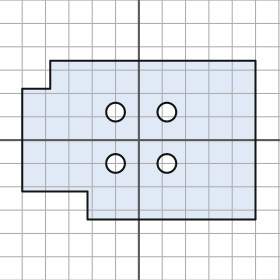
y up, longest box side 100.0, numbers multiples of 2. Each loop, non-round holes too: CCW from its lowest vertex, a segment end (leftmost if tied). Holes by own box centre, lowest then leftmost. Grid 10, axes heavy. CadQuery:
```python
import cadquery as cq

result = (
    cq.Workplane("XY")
    .moveTo(-22.0, -34.0)
    .lineTo(50.0, -34.0)
    .lineTo(50.0, 34.0)
    .lineTo(-38.0, 34.0)
    .lineTo(-38.0, 22.0)
    .lineTo(-50.0, 22.0)
    .lineTo(-50.0, -22.0)
    .lineTo(-22.0, -22.0)
    .close()
    .moveTo(-10.0, -10.0)
    .circle(4.0)
    .moveTo(12.0, -10.0)
    .circle(4.0)
    .moveTo(-10.0, 12.0)
    .circle(4.0)
    .moveTo(12.0, 12.0)
    .circle(4.0)
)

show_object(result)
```